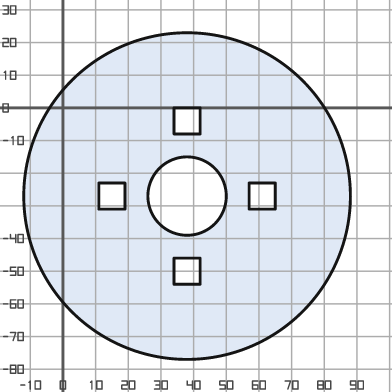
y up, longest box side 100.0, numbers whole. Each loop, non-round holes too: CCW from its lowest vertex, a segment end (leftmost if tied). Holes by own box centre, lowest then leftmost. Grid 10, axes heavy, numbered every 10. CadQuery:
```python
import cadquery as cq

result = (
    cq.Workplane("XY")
    .moveTo(38.0, -27.0)
    .circle(50.0)
    .moveTo(34.0, -54.0)
    .lineTo(42.0, -54.0)
    .lineTo(42.0, -46.0)
    .lineTo(34.0, -46.0)
    .close()
    .moveTo(11.0, -31.0)
    .lineTo(19.0, -31.0)
    .lineTo(19.0, -23.0)
    .lineTo(11.0, -23.0)
    .close()
    .moveTo(38.0, -27.0)
    .circle(12.0)
    .moveTo(57.0, -31.0)
    .lineTo(65.0, -31.0)
    .lineTo(65.0, -23.0)
    .lineTo(57.0, -23.0)
    .close()
    .moveTo(34.0, -8.0)
    .lineTo(42.0, -8.0)
    .lineTo(42.0, 0.0)
    .lineTo(34.0, 0.0)
    .close()
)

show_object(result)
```